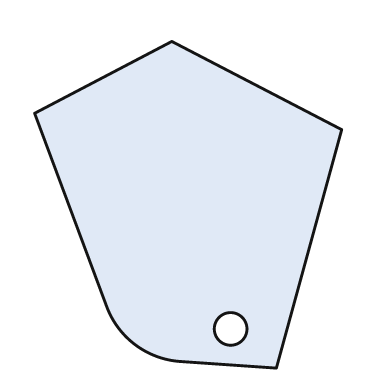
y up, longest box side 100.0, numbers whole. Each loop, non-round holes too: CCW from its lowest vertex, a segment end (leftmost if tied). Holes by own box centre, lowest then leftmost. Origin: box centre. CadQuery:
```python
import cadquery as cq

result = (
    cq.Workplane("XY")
    .moveTo(27.0, -50.0)
    .lineTo(47.0, 23.0)
    .lineTo(-5.0, 50.0)
    .lineTo(-47.0, 28.0)
    .lineTo(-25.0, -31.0)
    .threePointArc((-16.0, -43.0), (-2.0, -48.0))
    .close()
    .moveTo(13.0, -38.0)
    .circle(5.0)
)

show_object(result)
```